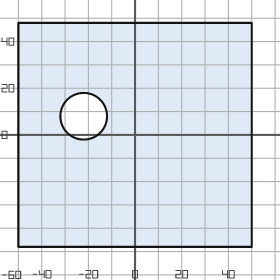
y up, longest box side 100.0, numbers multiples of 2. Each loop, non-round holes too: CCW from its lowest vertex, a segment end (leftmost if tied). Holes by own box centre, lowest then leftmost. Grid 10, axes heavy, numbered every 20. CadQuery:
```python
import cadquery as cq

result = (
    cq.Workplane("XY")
    .moveTo(-50.0, -48.0)
    .lineTo(50.0, -48.0)
    .lineTo(50.0, 48.0)
    .lineTo(-50.0, 48.0)
    .close()
    .moveTo(-22.0, 8.0)
    .circle(10.0)
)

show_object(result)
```